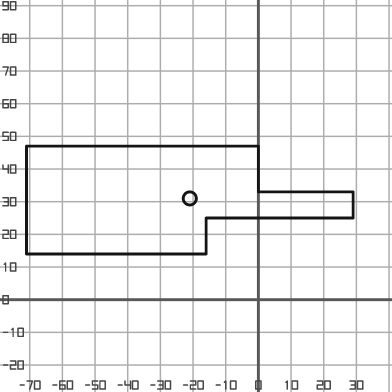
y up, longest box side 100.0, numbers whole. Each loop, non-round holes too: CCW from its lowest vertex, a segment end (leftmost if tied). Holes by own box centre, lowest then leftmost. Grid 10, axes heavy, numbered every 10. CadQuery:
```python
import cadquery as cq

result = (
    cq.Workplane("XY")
    .moveTo(-71.0, 14.0)
    .lineTo(-16.0, 14.0)
    .lineTo(-16.0, 25.0)
    .lineTo(29.0, 25.0)
    .lineTo(29.0, 33.0)
    .lineTo(0.0, 33.0)
    .lineTo(0.0, 47.0)
    .lineTo(-71.0, 47.0)
    .close()
    .moveTo(-21.0, 31.0)
    .circle(2.0)
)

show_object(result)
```